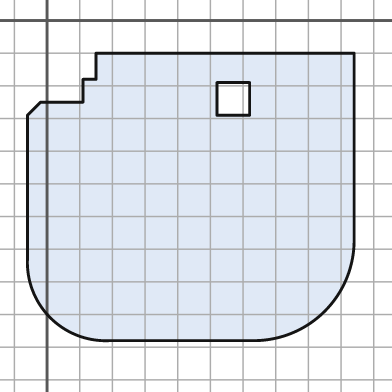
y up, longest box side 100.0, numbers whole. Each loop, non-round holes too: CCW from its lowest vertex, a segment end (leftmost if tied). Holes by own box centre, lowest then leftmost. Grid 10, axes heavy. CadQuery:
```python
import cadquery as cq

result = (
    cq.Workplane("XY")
    .moveTo(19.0, -98.0)
    .lineTo(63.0, -98.0)
    .threePointArc((85.0, -89.0), (94.0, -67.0))
    .lineTo(94.0, -10.0)
    .lineTo(15.0, -10.0)
    .lineTo(15.0, -18.0)
    .lineTo(11.0, -18.0)
    .lineTo(11.0, -25.0)
    .lineTo(-2.0, -25.0)
    .lineTo(-6.0, -29.0)
    .lineTo(-6.0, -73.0)
    .threePointArc((1.0, -91.0), (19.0, -98.0))
    .close()
    .moveTo(52.0, -29.0)
    .lineTo(62.0, -29.0)
    .lineTo(62.0, -19.0)
    .lineTo(52.0, -19.0)
    .close()
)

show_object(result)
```